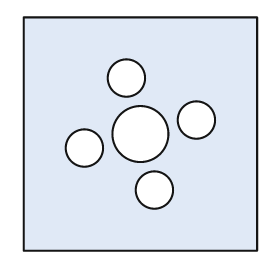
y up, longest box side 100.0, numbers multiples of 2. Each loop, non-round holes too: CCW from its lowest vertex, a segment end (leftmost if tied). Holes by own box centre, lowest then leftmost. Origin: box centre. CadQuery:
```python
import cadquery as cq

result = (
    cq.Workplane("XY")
    .moveTo(-50.0, -50.0)
    .lineTo(50.0, -50.0)
    .lineTo(50.0, 50.0)
    .lineTo(-50.0, 50.0)
    .close()
    .moveTo(6.0, -24.0)
    .circle(8.0)
    .moveTo(-24.0, -6.0)
    .circle(8.0)
    .moveTo(0.0, 0.0)
    .circle(12.0)
    .moveTo(24.0, 6.0)
    .circle(8.0)
    .moveTo(-6.0, 24.0)
    .circle(8.0)
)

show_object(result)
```